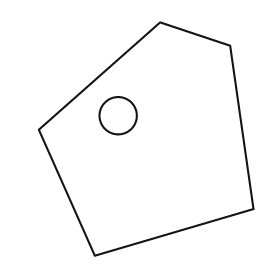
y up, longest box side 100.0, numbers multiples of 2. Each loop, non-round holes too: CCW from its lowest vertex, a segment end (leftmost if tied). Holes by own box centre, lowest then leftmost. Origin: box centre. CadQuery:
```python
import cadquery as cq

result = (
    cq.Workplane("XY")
    .moveTo(-22.0, -50.0)
    .lineTo(46.0, -30.0)
    .lineTo(36.0, 40.0)
    .lineTo(6.0, 50.0)
    .lineTo(-46.0, 4.0)
    .close()
    .moveTo(-12.0, 10.0)
    .circle(8.0)
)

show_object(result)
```